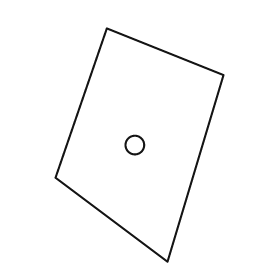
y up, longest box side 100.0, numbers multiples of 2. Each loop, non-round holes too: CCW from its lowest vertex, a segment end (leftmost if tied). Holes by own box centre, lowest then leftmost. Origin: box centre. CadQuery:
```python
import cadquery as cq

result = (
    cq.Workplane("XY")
    .moveTo(12.0, -50.0)
    .lineTo(36.0, 30.0)
    .lineTo(-14.0, 50.0)
    .lineTo(-36.0, -14.0)
    .close()
    .moveTo(-2.0, 0.0)
    .circle(4.0)
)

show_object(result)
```